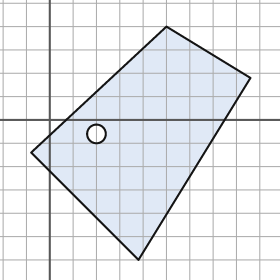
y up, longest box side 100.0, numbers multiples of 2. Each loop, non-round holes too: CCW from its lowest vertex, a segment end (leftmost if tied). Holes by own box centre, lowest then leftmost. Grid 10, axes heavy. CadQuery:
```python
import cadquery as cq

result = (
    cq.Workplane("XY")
    .moveTo(38.0, -60.0)
    .lineTo(86.0, 18.0)
    .lineTo(50.0, 40.0)
    .lineTo(-8.0, -14.0)
    .close()
    .moveTo(20.0, -6.0)
    .circle(4.0)
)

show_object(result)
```